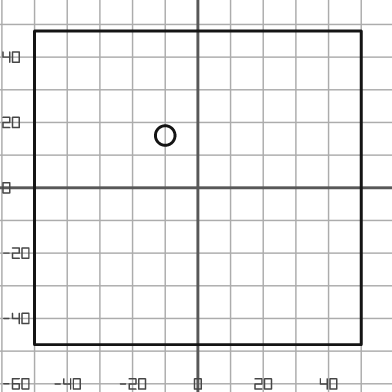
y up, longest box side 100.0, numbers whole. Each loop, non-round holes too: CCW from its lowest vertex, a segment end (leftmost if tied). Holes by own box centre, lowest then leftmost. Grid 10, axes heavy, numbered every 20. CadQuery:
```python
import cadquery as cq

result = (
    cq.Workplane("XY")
    .moveTo(-50.0, -48.0)
    .lineTo(50.0, -48.0)
    .lineTo(50.0, 48.0)
    .lineTo(-50.0, 48.0)
    .close()
    .moveTo(-10.0, 16.0)
    .circle(3.0)
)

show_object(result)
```